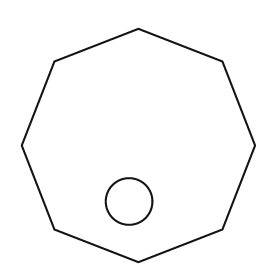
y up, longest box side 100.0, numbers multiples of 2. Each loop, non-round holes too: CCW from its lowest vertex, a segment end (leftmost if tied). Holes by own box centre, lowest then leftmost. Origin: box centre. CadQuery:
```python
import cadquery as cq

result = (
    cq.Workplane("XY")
    .moveTo(0.0, -50.0)
    .lineTo(36.0, -36.0)
    .lineTo(50.0, 0.0)
    .lineTo(36.0, 36.0)
    .lineTo(0.0, 50.0)
    .lineTo(-36.0, 36.0)
    .lineTo(-50.0, 0.0)
    .lineTo(-36.0, -36.0)
    .close()
    .moveTo(-4.0, -24.0)
    .circle(10.0)
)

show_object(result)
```